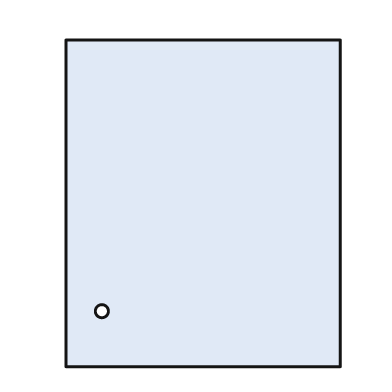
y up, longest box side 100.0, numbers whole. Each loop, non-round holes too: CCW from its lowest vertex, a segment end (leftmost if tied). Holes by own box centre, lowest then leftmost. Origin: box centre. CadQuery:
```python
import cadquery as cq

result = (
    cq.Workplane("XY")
    .moveTo(-42.0, -50.0)
    .lineTo(42.0, -50.0)
    .lineTo(42.0, 50.0)
    .lineTo(-42.0, 50.0)
    .close()
    .moveTo(-31.0, -33.0)
    .circle(2.0)
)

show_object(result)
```